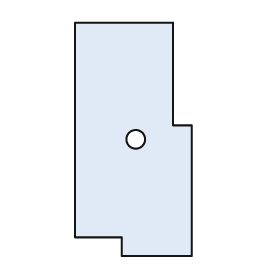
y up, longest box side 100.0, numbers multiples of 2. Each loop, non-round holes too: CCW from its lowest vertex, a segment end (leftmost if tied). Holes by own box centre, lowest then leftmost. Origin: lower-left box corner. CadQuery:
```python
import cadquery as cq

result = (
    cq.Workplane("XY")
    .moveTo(20.0, 0.0)
    .lineTo(50.0, 0.0)
    .lineTo(50.0, 56.0)
    .lineTo(42.0, 56.0)
    .lineTo(42.0, 100.0)
    .lineTo(0.0, 100.0)
    .lineTo(0.0, 8.0)
    .lineTo(20.0, 8.0)
    .close()
    .moveTo(26.0, 50.0)
    .circle(4.0)
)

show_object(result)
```